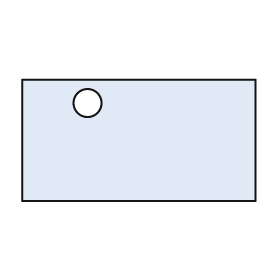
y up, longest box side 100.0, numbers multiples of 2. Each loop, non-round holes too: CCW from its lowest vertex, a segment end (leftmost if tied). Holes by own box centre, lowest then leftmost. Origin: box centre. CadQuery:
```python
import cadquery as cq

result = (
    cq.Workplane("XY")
    .moveTo(-50.0, -26.0)
    .lineTo(50.0, -26.0)
    .lineTo(50.0, 26.0)
    .lineTo(-50.0, 26.0)
    .close()
    .moveTo(-22.0, 16.0)
    .circle(6.0)
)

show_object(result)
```